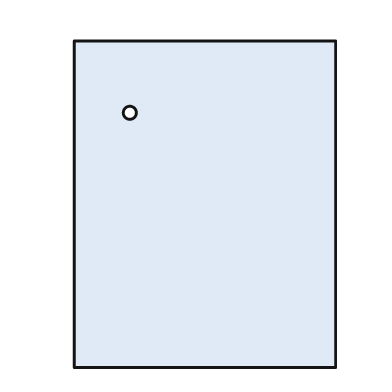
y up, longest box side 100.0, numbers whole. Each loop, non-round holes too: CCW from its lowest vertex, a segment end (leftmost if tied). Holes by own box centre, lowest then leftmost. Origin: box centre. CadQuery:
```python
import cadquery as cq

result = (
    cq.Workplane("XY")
    .moveTo(-40.0, -50.0)
    .lineTo(40.0, -50.0)
    .lineTo(40.0, 50.0)
    .lineTo(-40.0, 50.0)
    .close()
    .moveTo(-23.0, 28.0)
    .circle(2.0)
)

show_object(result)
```